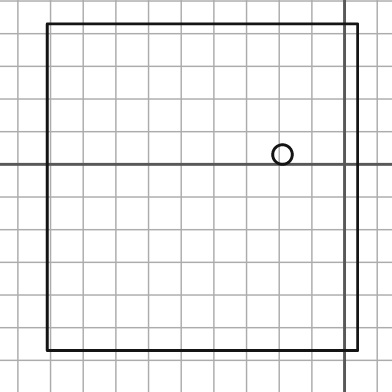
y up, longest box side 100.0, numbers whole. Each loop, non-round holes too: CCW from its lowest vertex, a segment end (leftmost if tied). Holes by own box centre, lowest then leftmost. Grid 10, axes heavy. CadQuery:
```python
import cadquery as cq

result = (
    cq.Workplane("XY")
    .moveTo(-91.0, -57.0)
    .lineTo(4.0, -57.0)
    .lineTo(4.0, 43.0)
    .lineTo(-91.0, 43.0)
    .close()
    .moveTo(-19.0, 3.0)
    .circle(3.0)
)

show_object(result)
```